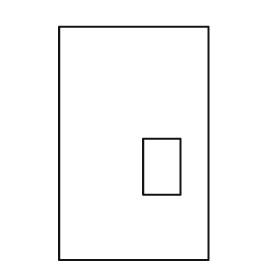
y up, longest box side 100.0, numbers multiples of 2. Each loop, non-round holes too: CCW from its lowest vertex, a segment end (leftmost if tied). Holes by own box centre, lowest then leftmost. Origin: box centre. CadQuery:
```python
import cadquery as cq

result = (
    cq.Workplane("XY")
    .moveTo(-32.0, -50.0)
    .lineTo(32.0, -50.0)
    .lineTo(32.0, 50.0)
    .lineTo(-32.0, 50.0)
    .close()
    .moveTo(4.0, -22.0)
    .lineTo(20.0, -22.0)
    .lineTo(20.0, 2.0)
    .lineTo(4.0, 2.0)
    .close()
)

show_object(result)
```